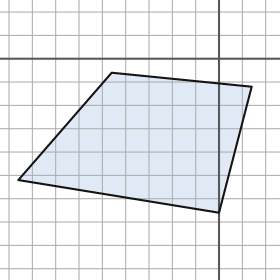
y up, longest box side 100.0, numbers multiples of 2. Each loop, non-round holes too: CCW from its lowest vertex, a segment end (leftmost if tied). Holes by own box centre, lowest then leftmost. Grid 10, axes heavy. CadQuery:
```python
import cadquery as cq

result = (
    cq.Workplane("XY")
    .moveTo(0.0, -66.0)
    .lineTo(14.0, -12.0)
    .lineTo(-46.0, -6.0)
    .lineTo(-86.0, -52.0)
    .close()
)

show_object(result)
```